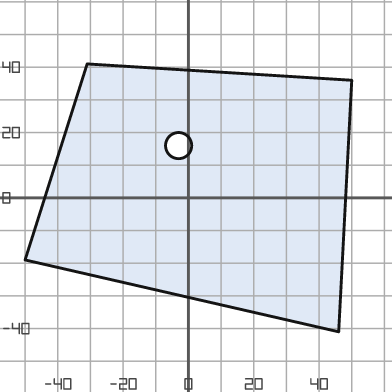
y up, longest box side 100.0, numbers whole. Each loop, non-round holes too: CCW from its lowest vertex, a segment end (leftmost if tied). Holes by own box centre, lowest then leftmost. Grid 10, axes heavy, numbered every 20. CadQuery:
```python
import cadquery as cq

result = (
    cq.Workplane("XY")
    .moveTo(46.0, -41.0)
    .lineTo(50.0, 36.0)
    .lineTo(-31.0, 41.0)
    .lineTo(-50.0, -19.0)
    .close()
    .moveTo(-3.0, 16.0)
    .circle(4.0)
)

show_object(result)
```